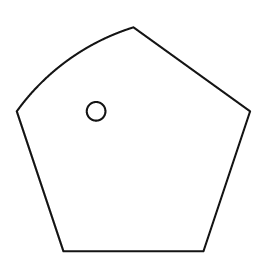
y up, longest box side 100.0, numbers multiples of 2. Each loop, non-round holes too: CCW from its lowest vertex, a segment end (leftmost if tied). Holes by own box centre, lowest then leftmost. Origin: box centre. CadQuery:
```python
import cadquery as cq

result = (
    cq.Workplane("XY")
    .moveTo(-30.0, -48.0)
    .lineTo(30.0, -48.0)
    .lineTo(50.0, 12.0)
    .lineTo(0.0, 48.0)
    .threePointArc((-28.0, 34.0), (-50.0, 12.0))
    .close()
    .moveTo(-16.0, 12.0)
    .circle(4.0)
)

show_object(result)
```